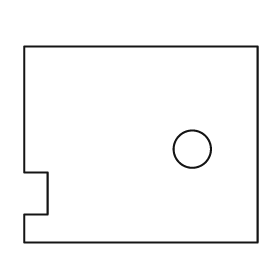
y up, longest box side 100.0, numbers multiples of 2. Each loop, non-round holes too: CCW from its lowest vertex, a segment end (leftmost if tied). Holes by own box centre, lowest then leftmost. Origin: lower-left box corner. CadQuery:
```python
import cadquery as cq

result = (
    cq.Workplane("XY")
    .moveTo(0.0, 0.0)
    .lineTo(100.0, 0.0)
    .lineTo(100.0, 84.0)
    .lineTo(0.0, 84.0)
    .lineTo(0.0, 30.0)
    .lineTo(10.0, 30.0)
    .lineTo(10.0, 12.0)
    .lineTo(0.0, 12.0)
    .close()
    .moveTo(72.0, 40.0)
    .circle(8.0)
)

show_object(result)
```